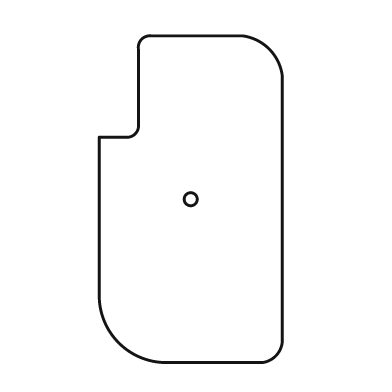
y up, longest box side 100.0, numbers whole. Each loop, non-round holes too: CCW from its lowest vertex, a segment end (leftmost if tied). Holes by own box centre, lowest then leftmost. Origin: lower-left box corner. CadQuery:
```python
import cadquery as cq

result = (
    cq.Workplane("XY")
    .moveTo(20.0, 0.0)
    .lineTo(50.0, 0.0)
    .threePointArc((54.0, 2.0), (56.0, 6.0))
    .lineTo(56.0, 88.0)
    .threePointArc((52.0, 96.0), (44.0, 100.0))
    .lineTo(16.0, 100.0)
    .threePointArc((13.0, 99.0), (12.0, 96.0))
    .lineTo(12.0, 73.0)
    .threePointArc((11.0, 70.0), (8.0, 69.0))
    .lineTo(0.0, 69.0)
    .lineTo(0.0, 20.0)
    .threePointArc((6.0, 6.0), (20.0, 0.0))
    .close()
    .moveTo(28.0, 50.0)
    .circle(2.0)
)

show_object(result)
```